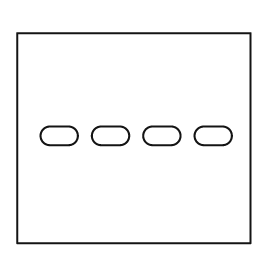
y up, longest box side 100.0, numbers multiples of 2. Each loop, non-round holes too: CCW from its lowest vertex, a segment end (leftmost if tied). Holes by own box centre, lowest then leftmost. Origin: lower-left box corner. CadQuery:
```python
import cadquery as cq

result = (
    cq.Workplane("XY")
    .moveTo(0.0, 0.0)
    .lineTo(100.0, 0.0)
    .lineTo(100.0, 90.0)
    .lineTo(0.0, 90.0)
    .close()
    .moveTo(14.0, 42.0)
    .lineTo(22.0, 42.0)
    .threePointArc((26.0, 46.0), (22.0, 50.0))
    .lineTo(14.0, 50.0)
    .threePointArc((10.0, 46.0), (14.0, 42.0))
    .close()
    .moveTo(36.0, 42.0)
    .lineTo(44.0, 42.0)
    .threePointArc((48.0, 46.0), (44.0, 50.0))
    .lineTo(36.0, 50.0)
    .threePointArc((32.0, 46.0), (36.0, 42.0))
    .close()
    .moveTo(58.0, 42.0)
    .lineTo(66.0, 42.0)
    .threePointArc((70.0, 46.0), (66.0, 50.0))
    .lineTo(58.0, 50.0)
    .threePointArc((54.0, 46.0), (58.0, 42.0))
    .close()
    .moveTo(80.0, 42.0)
    .lineTo(88.0, 42.0)
    .threePointArc((92.0, 46.0), (88.0, 50.0))
    .lineTo(80.0, 50.0)
    .threePointArc((76.0, 46.0), (80.0, 42.0))
    .close()
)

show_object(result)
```